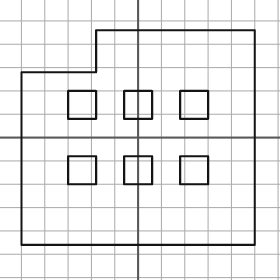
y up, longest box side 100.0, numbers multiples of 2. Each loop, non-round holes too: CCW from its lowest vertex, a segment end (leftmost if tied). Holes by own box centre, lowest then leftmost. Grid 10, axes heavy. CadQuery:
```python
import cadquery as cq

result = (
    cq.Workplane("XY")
    .moveTo(-50.0, -46.0)
    .lineTo(50.0, -46.0)
    .lineTo(50.0, 46.0)
    .lineTo(-18.0, 46.0)
    .lineTo(-18.0, 28.0)
    .lineTo(-50.0, 28.0)
    .close()
    .moveTo(-30.0, -20.0)
    .lineTo(-18.0, -20.0)
    .lineTo(-18.0, -8.0)
    .lineTo(-30.0, -8.0)
    .close()
    .moveTo(-6.0, -20.0)
    .lineTo(6.0, -20.0)
    .lineTo(6.0, -8.0)
    .lineTo(-6.0, -8.0)
    .close()
    .moveTo(18.0, -20.0)
    .lineTo(30.0, -20.0)
    .lineTo(30.0, -8.0)
    .lineTo(18.0, -8.0)
    .close()
    .moveTo(-30.0, 8.0)
    .lineTo(-18.0, 8.0)
    .lineTo(-18.0, 20.0)
    .lineTo(-30.0, 20.0)
    .close()
    .moveTo(-6.0, 8.0)
    .lineTo(6.0, 8.0)
    .lineTo(6.0, 20.0)
    .lineTo(-6.0, 20.0)
    .close()
    .moveTo(18.0, 8.0)
    .lineTo(30.0, 8.0)
    .lineTo(30.0, 20.0)
    .lineTo(18.0, 20.0)
    .close()
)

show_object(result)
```